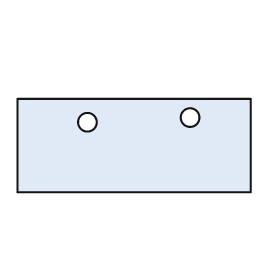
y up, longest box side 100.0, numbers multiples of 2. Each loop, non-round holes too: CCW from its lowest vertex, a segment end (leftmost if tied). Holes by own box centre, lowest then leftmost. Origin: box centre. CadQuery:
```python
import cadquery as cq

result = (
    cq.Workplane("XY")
    .moveTo(-50.0, -20.0)
    .lineTo(50.0, -20.0)
    .lineTo(50.0, 20.0)
    .lineTo(-50.0, 20.0)
    .close()
    .moveTo(-20.0, 10.0)
    .circle(4.0)
    .moveTo(24.0, 12.0)
    .circle(4.0)
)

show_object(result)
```